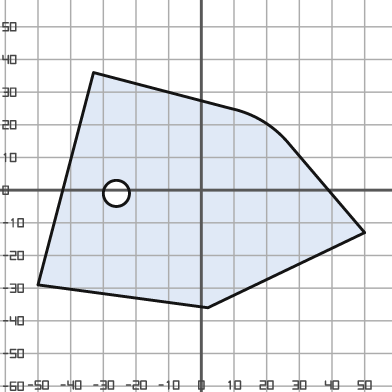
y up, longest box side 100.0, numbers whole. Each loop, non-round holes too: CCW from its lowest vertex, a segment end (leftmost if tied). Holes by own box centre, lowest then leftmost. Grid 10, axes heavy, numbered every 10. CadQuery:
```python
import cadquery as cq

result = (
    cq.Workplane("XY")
    .moveTo(2.0, -36.0)
    .lineTo(50.0, -13.0)
    .lineTo(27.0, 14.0)
    .threePointArc((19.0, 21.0), (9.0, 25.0))
    .lineTo(-33.0, 36.0)
    .lineTo(-50.0, -29.0)
    .close()
    .moveTo(-26.0, -1.0)
    .circle(4.0)
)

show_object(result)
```